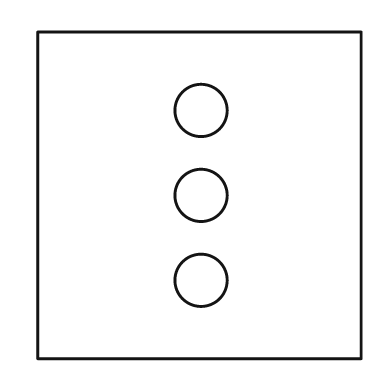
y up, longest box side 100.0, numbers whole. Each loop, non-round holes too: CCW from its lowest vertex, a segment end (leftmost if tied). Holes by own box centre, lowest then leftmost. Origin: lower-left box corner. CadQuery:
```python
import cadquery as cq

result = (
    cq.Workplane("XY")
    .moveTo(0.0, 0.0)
    .lineTo(99.0, 0.0)
    .lineTo(99.0, 100.0)
    .lineTo(0.0, 100.0)
    .close()
    .moveTo(50.0, 24.0)
    .circle(8.0)
    .moveTo(50.0, 50.0)
    .circle(8.0)
    .moveTo(50.0, 76.0)
    .circle(8.0)
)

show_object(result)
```